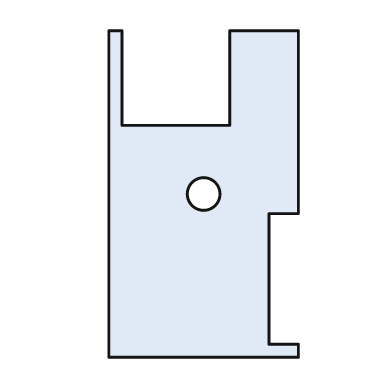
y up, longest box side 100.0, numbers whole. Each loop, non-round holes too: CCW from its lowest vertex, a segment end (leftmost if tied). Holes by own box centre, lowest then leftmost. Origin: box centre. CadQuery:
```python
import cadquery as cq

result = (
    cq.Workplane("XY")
    .moveTo(-29.0, -50.0)
    .lineTo(29.0, -50.0)
    .lineTo(29.0, -46.0)
    .lineTo(20.0, -46.0)
    .lineTo(20.0, -6.0)
    .lineTo(29.0, -6.0)
    .lineTo(29.0, 50.0)
    .lineTo(8.0, 50.0)
    .lineTo(8.0, 21.0)
    .lineTo(-25.0, 21.0)
    .lineTo(-25.0, 50.0)
    .lineTo(-29.0, 50.0)
    .close()
    .moveTo(0.0, 0.0)
    .circle(5.0)
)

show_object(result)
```